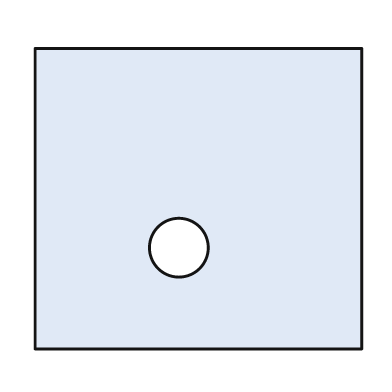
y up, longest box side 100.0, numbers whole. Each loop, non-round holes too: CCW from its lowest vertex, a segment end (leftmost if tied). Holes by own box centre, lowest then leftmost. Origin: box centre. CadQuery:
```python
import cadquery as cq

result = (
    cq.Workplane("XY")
    .moveTo(-50.0, -46.0)
    .lineTo(50.0, -46.0)
    .lineTo(50.0, 46.0)
    .lineTo(-50.0, 46.0)
    .close()
    .moveTo(-6.0, -15.0)
    .circle(9.0)
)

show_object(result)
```